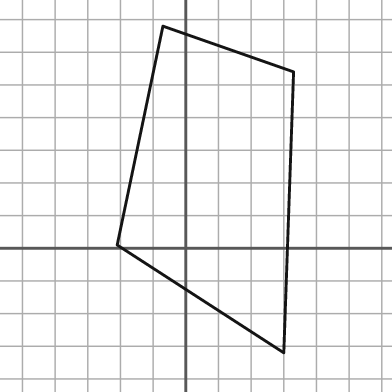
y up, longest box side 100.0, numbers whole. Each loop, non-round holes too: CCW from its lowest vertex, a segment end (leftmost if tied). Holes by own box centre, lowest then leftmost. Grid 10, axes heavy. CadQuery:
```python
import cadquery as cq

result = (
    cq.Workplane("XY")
    .moveTo(30.0, -32.0)
    .lineTo(33.0, 54.0)
    .lineTo(-7.0, 68.0)
    .lineTo(-21.0, 1.0)
    .close()
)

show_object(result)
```